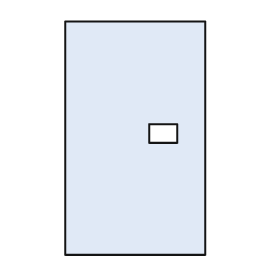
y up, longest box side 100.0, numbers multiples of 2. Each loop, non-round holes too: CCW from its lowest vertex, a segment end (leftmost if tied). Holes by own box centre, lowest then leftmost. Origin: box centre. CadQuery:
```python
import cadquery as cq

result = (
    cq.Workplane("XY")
    .moveTo(-30.0, -50.0)
    .lineTo(30.0, -50.0)
    .lineTo(30.0, 50.0)
    .lineTo(-30.0, 50.0)
    .close()
    .moveTo(6.0, -2.0)
    .lineTo(18.0, -2.0)
    .lineTo(18.0, 6.0)
    .lineTo(6.0, 6.0)
    .close()
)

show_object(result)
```